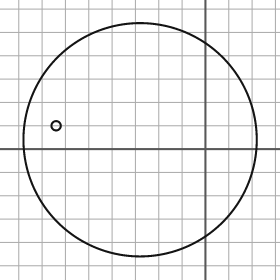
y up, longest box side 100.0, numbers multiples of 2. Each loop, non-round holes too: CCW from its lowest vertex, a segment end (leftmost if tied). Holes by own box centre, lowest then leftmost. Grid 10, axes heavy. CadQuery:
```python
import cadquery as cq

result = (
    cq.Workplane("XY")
    .moveTo(-28.0, 4.0)
    .circle(50.0)
    .moveTo(-64.0, 10.0)
    .circle(2.0)
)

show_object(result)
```